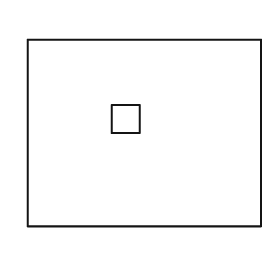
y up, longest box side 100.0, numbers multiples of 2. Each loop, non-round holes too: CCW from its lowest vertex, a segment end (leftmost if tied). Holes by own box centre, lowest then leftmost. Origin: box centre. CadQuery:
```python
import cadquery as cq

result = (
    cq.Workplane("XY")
    .moveTo(-50.0, -40.0)
    .lineTo(50.0, -40.0)
    .lineTo(50.0, 40.0)
    .lineTo(-50.0, 40.0)
    .close()
    .moveTo(-14.0, 0.0)
    .lineTo(-2.0, 0.0)
    .lineTo(-2.0, 12.0)
    .lineTo(-14.0, 12.0)
    .close()
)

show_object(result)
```